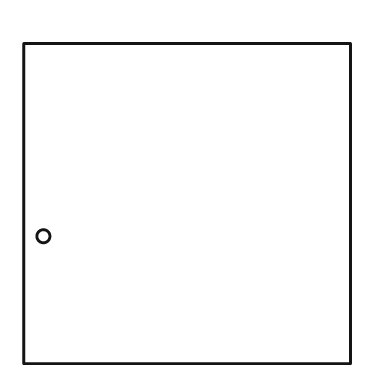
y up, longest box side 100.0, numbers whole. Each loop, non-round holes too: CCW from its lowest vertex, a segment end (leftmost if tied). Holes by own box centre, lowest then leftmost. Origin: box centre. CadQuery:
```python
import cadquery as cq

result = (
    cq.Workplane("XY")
    .moveTo(-50.0, -49.0)
    .lineTo(50.0, -49.0)
    .lineTo(50.0, 49.0)
    .lineTo(-50.0, 49.0)
    .close()
    .moveTo(-44.0, -10.0)
    .circle(2.0)
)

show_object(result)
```